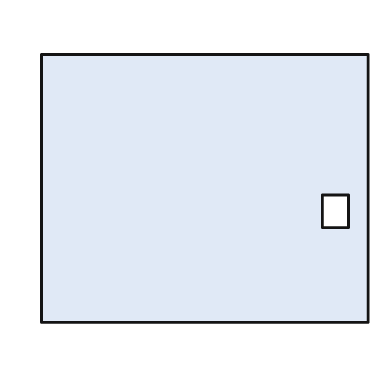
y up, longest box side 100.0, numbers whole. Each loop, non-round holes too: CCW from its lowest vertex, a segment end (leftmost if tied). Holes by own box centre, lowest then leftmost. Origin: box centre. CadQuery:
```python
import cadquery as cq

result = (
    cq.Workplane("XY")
    .moveTo(-50.0, -41.0)
    .lineTo(50.0, -41.0)
    .lineTo(50.0, 41.0)
    .lineTo(-50.0, 41.0)
    .close()
    .moveTo(36.0, -12.0)
    .lineTo(44.0, -12.0)
    .lineTo(44.0, -2.0)
    .lineTo(36.0, -2.0)
    .close()
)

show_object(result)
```